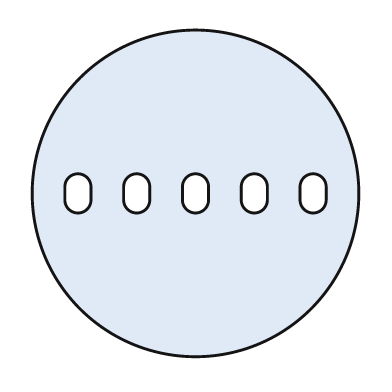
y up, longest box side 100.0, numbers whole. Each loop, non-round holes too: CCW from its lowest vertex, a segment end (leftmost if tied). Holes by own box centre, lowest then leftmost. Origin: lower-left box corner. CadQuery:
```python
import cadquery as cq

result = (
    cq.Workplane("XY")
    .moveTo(50.0, 50.0)
    .circle(50.0)
    .moveTo(10.0, 48.0)
    .threePointArc((14.0, 44.0), (18.0, 48.0))
    .lineTo(18.0, 52.0)
    .threePointArc((14.0, 56.0), (10.0, 52.0))
    .close()
    .moveTo(28.0, 48.0)
    .threePointArc((32.0, 44.0), (36.0, 48.0))
    .lineTo(36.0, 52.0)
    .threePointArc((32.0, 56.0), (28.0, 52.0))
    .close()
    .moveTo(46.0, 48.0)
    .threePointArc((50.0, 44.0), (54.0, 48.0))
    .lineTo(54.0, 52.0)
    .threePointArc((50.0, 56.0), (46.0, 52.0))
    .close()
    .moveTo(64.0, 48.0)
    .threePointArc((68.0, 44.0), (72.0, 48.0))
    .lineTo(72.0, 52.0)
    .threePointArc((68.0, 56.0), (64.0, 52.0))
    .close()
    .moveTo(82.0, 48.0)
    .threePointArc((86.0, 44.0), (90.0, 48.0))
    .lineTo(90.0, 52.0)
    .threePointArc((86.0, 56.0), (82.0, 52.0))
    .close()
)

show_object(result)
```